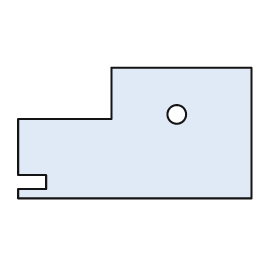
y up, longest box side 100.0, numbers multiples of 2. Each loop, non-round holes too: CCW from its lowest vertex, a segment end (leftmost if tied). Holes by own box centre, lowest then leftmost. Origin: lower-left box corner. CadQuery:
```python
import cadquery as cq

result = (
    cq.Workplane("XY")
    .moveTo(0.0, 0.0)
    .lineTo(100.0, 0.0)
    .lineTo(100.0, 56.0)
    .lineTo(40.0, 56.0)
    .lineTo(40.0, 34.0)
    .lineTo(0.0, 34.0)
    .lineTo(0.0, 10.0)
    .lineTo(12.0, 10.0)
    .lineTo(12.0, 4.0)
    .lineTo(0.0, 4.0)
    .close()
    .moveTo(68.0, 36.0)
    .circle(4.0)
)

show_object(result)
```